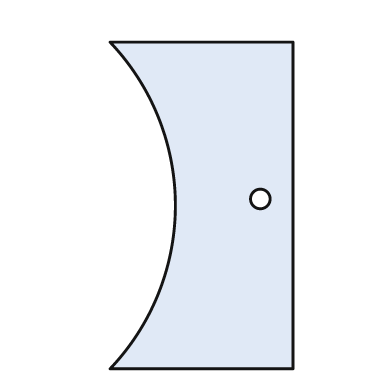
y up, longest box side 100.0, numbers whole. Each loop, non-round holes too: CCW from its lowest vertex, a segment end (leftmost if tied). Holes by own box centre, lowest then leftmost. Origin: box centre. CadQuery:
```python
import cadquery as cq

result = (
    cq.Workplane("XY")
    .moveTo(-28.0, -50.0)
    .lineTo(28.0, -50.0)
    .lineTo(28.0, 50.0)
    .lineTo(-28.0, 50.0)
    .threePointArc((-8.0, 0.0), (-28.0, -50.0))
    .close()
    .moveTo(18.0, 2.0)
    .circle(3.0)
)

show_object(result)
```